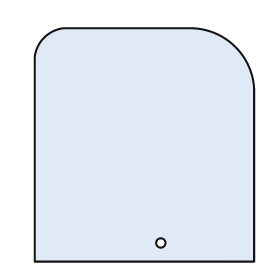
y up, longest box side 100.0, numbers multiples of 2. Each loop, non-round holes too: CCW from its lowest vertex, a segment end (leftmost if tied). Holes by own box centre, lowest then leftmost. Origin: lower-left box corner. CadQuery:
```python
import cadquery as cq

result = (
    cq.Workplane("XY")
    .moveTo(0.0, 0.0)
    .lineTo(94.0, 0.0)
    .lineTo(94.0, 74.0)
    .threePointArc((86.0, 92.0), (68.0, 100.0))
    .lineTo(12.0, 100.0)
    .threePointArc((4.0, 96.0), (0.0, 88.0))
    .close()
    .moveTo(54.0, 8.0)
    .circle(2.0)
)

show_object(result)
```